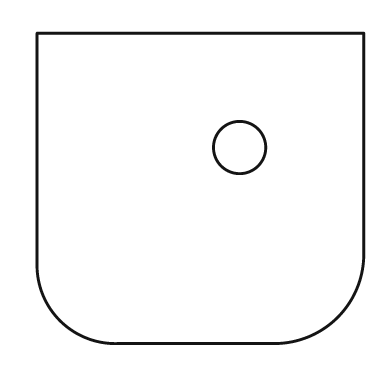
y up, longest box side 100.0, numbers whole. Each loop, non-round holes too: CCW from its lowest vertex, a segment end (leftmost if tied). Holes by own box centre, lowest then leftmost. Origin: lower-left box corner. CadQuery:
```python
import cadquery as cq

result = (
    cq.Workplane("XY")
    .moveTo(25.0, 0.0)
    .lineTo(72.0, 0.0)
    .threePointArc((92.0, 8.0), (100.0, 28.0))
    .lineTo(100.0, 95.0)
    .lineTo(0.0, 95.0)
    .lineTo(0.0, 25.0)
    .threePointArc((7.0, 7.0), (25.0, 0.0))
    .close()
    .moveTo(62.0, 60.0)
    .circle(8.0)
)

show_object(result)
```